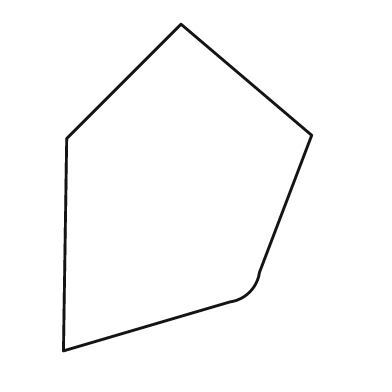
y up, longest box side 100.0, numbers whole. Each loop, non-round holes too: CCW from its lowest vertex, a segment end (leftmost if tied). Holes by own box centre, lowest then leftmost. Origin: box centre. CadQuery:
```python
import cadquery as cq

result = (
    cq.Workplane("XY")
    .moveTo(-38.0, -50.0)
    .lineTo(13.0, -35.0)
    .threePointArc((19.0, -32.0), (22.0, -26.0))
    .lineTo(38.0, 16.0)
    .lineTo(-2.0, 50.0)
    .lineTo(-37.0, 15.0)
    .close()
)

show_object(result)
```